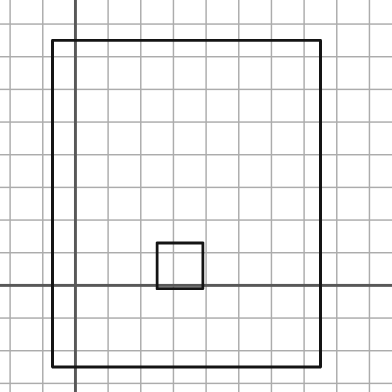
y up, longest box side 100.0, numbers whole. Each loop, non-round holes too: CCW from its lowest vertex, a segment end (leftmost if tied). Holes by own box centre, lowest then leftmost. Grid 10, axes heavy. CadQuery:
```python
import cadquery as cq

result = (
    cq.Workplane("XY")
    .moveTo(-7.0, -25.0)
    .lineTo(75.0, -25.0)
    .lineTo(75.0, 75.0)
    .lineTo(-7.0, 75.0)
    .close()
    .moveTo(25.0, -1.0)
    .lineTo(39.0, -1.0)
    .lineTo(39.0, 13.0)
    .lineTo(25.0, 13.0)
    .close()
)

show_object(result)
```